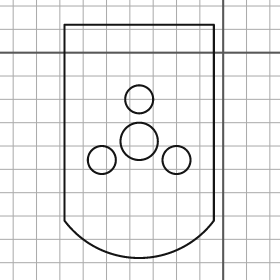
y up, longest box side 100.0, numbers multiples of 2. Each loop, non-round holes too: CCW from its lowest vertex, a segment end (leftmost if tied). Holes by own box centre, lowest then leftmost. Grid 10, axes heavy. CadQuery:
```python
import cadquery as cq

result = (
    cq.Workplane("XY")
    .moveTo(-68.0, -72.0)
    .threePointArc((-36.0, -88.0), (-4.0, -72.0))
    .lineTo(-4.0, 12.0)
    .lineTo(-68.0, 12.0)
    .close()
    .moveTo(-52.0, -46.0)
    .circle(6.0)
    .moveTo(-20.0, -46.0)
    .circle(6.0)
    .moveTo(-36.0, -38.0)
    .circle(8.0)
    .moveTo(-36.0, -20.0)
    .circle(6.0)
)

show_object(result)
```